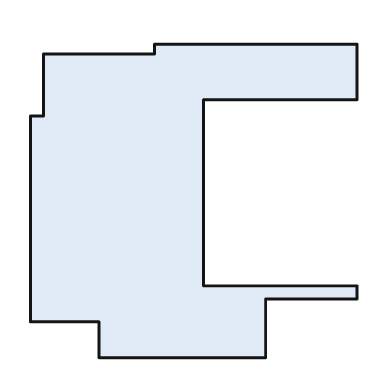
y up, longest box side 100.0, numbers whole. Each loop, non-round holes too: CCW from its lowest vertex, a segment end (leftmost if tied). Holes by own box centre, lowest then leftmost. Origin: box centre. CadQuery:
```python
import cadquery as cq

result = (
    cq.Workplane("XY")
    .moveTo(-29.0, -48.0)
    .lineTo(22.0, -48.0)
    .lineTo(22.0, -30.0)
    .lineTo(50.0, -30.0)
    .lineTo(50.0, -26.0)
    .lineTo(3.0, -26.0)
    .lineTo(3.0, 31.0)
    .lineTo(50.0, 31.0)
    .lineTo(50.0, 48.0)
    .lineTo(-12.0, 48.0)
    .lineTo(-12.0, 45.0)
    .lineTo(-46.0, 45.0)
    .lineTo(-46.0, 26.0)
    .lineTo(-50.0, 26.0)
    .lineTo(-50.0, -37.0)
    .lineTo(-29.0, -37.0)
    .close()
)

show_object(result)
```